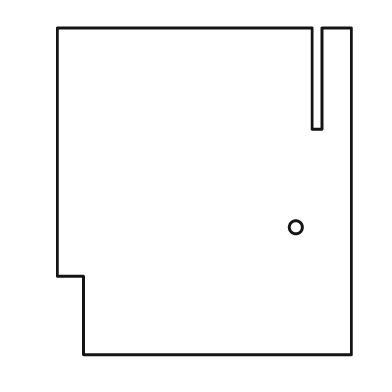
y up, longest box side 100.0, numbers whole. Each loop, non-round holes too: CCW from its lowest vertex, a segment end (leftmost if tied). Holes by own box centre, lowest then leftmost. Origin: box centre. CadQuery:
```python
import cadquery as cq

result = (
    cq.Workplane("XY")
    .moveTo(-37.0, -50.0)
    .lineTo(45.0, -50.0)
    .lineTo(45.0, 50.0)
    .lineTo(36.0, 50.0)
    .lineTo(36.0, 19.0)
    .lineTo(33.0, 19.0)
    .lineTo(33.0, 50.0)
    .lineTo(-45.0, 50.0)
    .lineTo(-45.0, -26.0)
    .lineTo(-37.0, -26.0)
    .close()
    .moveTo(28.0, -11.0)
    .circle(2.0)
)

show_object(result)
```